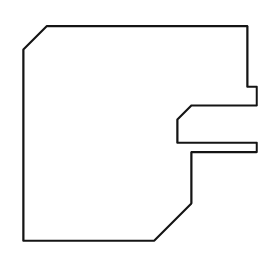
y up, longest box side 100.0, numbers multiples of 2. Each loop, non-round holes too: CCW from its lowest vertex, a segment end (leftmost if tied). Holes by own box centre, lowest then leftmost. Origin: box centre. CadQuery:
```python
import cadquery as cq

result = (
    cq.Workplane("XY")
    .moveTo(-50.0, -46.0)
    .lineTo(6.0, -46.0)
    .lineTo(22.0, -30.0)
    .lineTo(22.0, -8.0)
    .lineTo(50.0, -8.0)
    .lineTo(50.0, -4.0)
    .lineTo(16.0, -4.0)
    .lineTo(16.0, 6.0)
    .lineTo(22.0, 12.0)
    .lineTo(50.0, 12.0)
    .lineTo(50.0, 20.0)
    .lineTo(46.0, 20.0)
    .lineTo(46.0, 46.0)
    .lineTo(-40.0, 46.0)
    .lineTo(-50.0, 36.0)
    .close()
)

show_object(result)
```